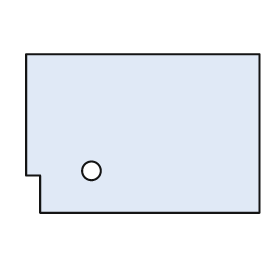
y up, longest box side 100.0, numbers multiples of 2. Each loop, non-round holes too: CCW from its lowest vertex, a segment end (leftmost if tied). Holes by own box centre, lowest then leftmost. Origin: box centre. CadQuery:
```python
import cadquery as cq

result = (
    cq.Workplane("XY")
    .moveTo(-44.0, -34.0)
    .lineTo(50.0, -34.0)
    .lineTo(50.0, 34.0)
    .lineTo(-50.0, 34.0)
    .lineTo(-50.0, -18.0)
    .lineTo(-44.0, -18.0)
    .close()
    .moveTo(-22.0, -16.0)
    .circle(4.0)
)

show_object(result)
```